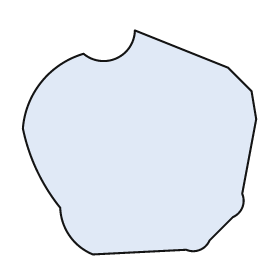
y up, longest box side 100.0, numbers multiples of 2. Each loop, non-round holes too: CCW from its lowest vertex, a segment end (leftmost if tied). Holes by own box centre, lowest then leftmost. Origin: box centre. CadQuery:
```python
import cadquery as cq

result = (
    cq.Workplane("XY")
    .moveTo(-20.0, -48.0)
    .lineTo(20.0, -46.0)
    .threePointArc((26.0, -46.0), (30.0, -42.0))
    .lineTo(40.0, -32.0)
    .threePointArc((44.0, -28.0), (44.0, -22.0))
    .lineTo(50.0, 10.0)
    .lineTo(48.0, 22.0)
    .lineTo(38.0, 32.0)
    .lineTo(-2.0, 48.0)
    .threePointArc((-10.0, 36.0), (-24.0, 38.0))
    .threePointArc((-42.0, 26.0), (-50.0, 6.0))
    .threePointArc((-44.0, -12.0), (-34.0, -28.0))
    .threePointArc((-30.0, -40.0), (-20.0, -48.0))
    .close()
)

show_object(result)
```